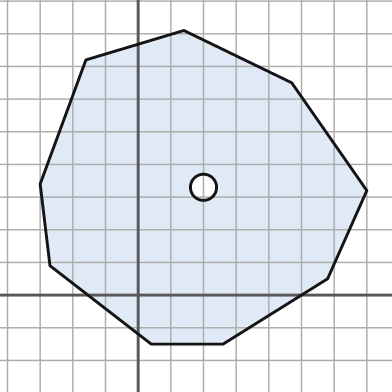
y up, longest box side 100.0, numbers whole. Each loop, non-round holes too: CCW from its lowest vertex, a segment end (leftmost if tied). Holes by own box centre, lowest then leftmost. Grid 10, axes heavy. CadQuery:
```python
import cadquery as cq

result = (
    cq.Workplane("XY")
    .moveTo(4.0, -15.0)
    .lineTo(26.0, -15.0)
    .lineTo(58.0, 5.0)
    .lineTo(70.0, 32.0)
    .lineTo(47.0, 65.0)
    .lineTo(14.0, 81.0)
    .lineTo(-16.0, 72.0)
    .lineTo(-30.0, 34.0)
    .lineTo(-27.0, 9.0)
    .close()
    .moveTo(20.0, 33.0)
    .circle(4.0)
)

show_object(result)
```